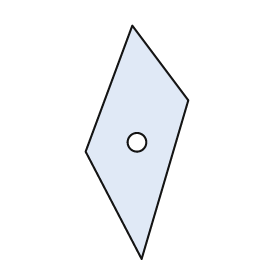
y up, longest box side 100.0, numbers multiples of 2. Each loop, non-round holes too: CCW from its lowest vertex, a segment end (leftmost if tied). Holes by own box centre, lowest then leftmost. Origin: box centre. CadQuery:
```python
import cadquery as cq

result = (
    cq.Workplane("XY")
    .moveTo(2.0, -50.0)
    .lineTo(22.0, 18.0)
    .lineTo(-2.0, 50.0)
    .lineTo(-22.0, -4.0)
    .close()
    .moveTo(0.0, 0.0)
    .circle(4.0)
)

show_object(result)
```